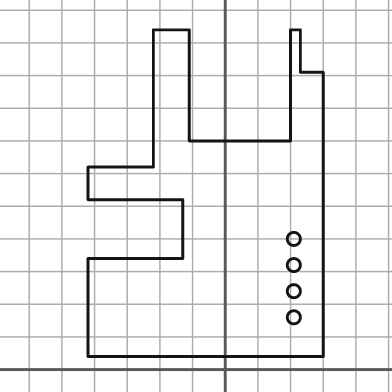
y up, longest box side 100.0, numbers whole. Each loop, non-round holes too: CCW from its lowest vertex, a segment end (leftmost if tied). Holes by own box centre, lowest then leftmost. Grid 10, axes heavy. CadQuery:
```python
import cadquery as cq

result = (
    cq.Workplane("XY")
    .moveTo(-42.0, 4.0)
    .lineTo(30.0, 4.0)
    .lineTo(30.0, 91.0)
    .lineTo(23.0, 91.0)
    .lineTo(23.0, 104.0)
    .lineTo(20.0, 104.0)
    .lineTo(20.0, 70.0)
    .lineTo(-11.0, 70.0)
    .lineTo(-11.0, 104.0)
    .lineTo(-22.0, 104.0)
    .lineTo(-22.0, 62.0)
    .lineTo(-42.0, 62.0)
    .lineTo(-42.0, 52.0)
    .lineTo(-13.0, 52.0)
    .lineTo(-13.0, 34.0)
    .lineTo(-42.0, 34.0)
    .close()
    .moveTo(21.0, 16.0)
    .circle(2.0)
    .moveTo(21.0, 24.0)
    .circle(2.0)
    .moveTo(21.0, 32.0)
    .circle(2.0)
    .moveTo(21.0, 40.0)
    .circle(2.0)
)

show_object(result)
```